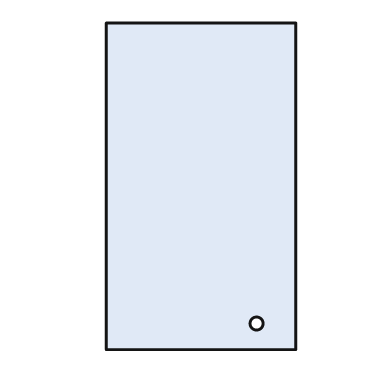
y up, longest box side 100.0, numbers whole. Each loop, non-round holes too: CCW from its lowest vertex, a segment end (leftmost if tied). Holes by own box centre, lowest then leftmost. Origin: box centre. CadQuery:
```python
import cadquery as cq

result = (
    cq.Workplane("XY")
    .moveTo(-29.0, -50.0)
    .lineTo(29.0, -50.0)
    .lineTo(29.0, 50.0)
    .lineTo(-29.0, 50.0)
    .close()
    .moveTo(17.0, -42.0)
    .circle(2.0)
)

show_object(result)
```